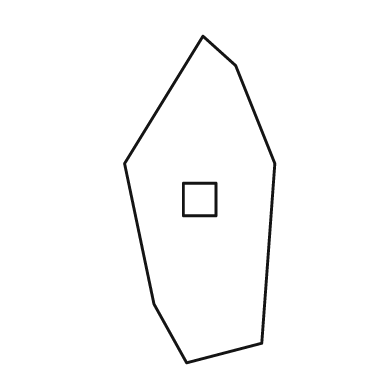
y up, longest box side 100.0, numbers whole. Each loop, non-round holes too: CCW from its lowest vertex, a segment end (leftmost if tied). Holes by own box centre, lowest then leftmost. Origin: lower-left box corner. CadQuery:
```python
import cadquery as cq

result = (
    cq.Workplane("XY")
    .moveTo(19.0, 0.0)
    .lineTo(42.0, 6.0)
    .lineTo(46.0, 61.0)
    .lineTo(34.0, 91.0)
    .lineTo(24.0, 100.0)
    .lineTo(0.0, 61.0)
    .lineTo(9.0, 18.0)
    .close()
    .moveTo(18.0, 45.0)
    .lineTo(28.0, 45.0)
    .lineTo(28.0, 55.0)
    .lineTo(18.0, 55.0)
    .close()
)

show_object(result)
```